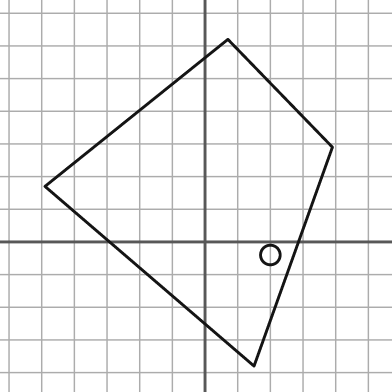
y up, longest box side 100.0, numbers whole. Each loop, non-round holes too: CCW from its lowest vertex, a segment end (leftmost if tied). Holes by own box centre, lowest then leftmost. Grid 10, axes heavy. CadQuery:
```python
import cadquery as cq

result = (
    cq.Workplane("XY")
    .moveTo(15.0, -38.0)
    .lineTo(39.0, 29.0)
    .lineTo(7.0, 62.0)
    .lineTo(-49.0, 17.0)
    .close()
    .moveTo(20.0, -4.0)
    .circle(3.0)
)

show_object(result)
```